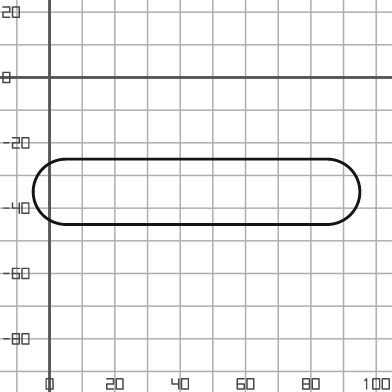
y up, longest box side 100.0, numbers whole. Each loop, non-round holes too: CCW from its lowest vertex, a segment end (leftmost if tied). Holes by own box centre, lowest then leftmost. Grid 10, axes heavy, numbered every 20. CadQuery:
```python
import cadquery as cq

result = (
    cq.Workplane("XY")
    .moveTo(5.0, -45.0)
    .lineTo(85.0, -45.0)
    .threePointArc((95.0, -35.0), (85.0, -25.0))
    .lineTo(5.0, -25.0)
    .threePointArc((-5.0, -35.0), (5.0, -45.0))
    .close()
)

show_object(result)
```